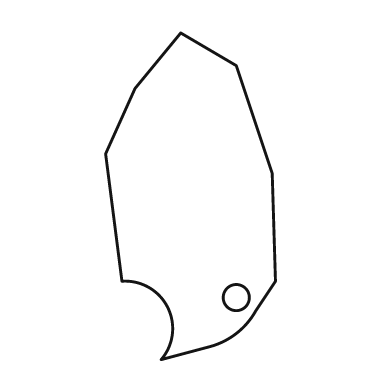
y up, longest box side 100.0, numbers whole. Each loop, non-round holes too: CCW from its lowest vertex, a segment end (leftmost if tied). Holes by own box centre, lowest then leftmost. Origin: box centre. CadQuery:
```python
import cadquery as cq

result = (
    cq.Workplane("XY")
    .moveTo(-9.0, -50.0)
    .lineTo(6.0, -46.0)
    .threePointArc((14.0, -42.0), (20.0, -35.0))
    .lineTo(26.0, -26.0)
    .lineTo(25.0, 7.0)
    .lineTo(14.0, 40.0)
    .lineTo(-3.0, 50.0)
    .lineTo(-17.0, 33.0)
    .lineTo(-26.0, 13.0)
    .lineTo(-21.0, -26.0)
    .threePointArc((-7.0, -34.0), (-9.0, -50.0))
    .close()
    .moveTo(14.0, -31.0)
    .circle(4.0)
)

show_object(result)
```